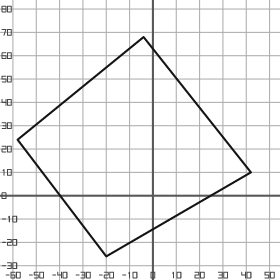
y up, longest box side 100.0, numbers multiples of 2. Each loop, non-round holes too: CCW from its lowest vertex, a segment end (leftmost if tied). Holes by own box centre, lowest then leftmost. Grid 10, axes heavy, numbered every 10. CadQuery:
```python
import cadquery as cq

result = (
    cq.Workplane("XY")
    .moveTo(-20.0, -26.0)
    .lineTo(42.0, 10.0)
    .lineTo(-4.0, 68.0)
    .lineTo(-58.0, 24.0)
    .close()
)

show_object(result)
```